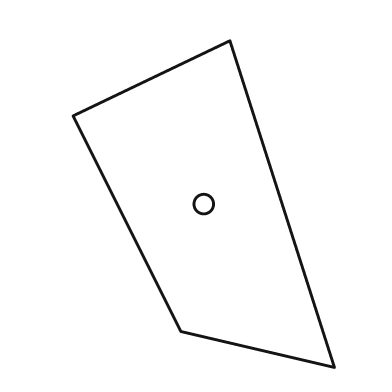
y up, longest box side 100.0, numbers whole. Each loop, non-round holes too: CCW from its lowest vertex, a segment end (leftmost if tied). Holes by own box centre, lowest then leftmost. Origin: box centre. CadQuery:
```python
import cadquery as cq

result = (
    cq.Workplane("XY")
    .moveTo(40.0, -50.0)
    .lineTo(8.0, 50.0)
    .lineTo(-40.0, 27.0)
    .lineTo(-7.0, -39.0)
    .close()
    .moveTo(0.0, 0.0)
    .circle(3.0)
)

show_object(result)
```